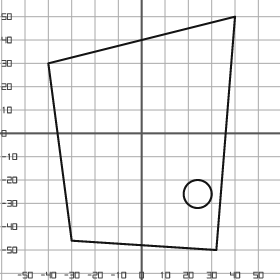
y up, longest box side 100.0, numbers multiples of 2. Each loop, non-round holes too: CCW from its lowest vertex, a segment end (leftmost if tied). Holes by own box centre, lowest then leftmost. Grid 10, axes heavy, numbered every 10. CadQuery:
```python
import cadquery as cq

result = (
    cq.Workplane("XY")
    .moveTo(32.0, -50.0)
    .lineTo(40.0, 50.0)
    .lineTo(-40.0, 30.0)
    .lineTo(-30.0, -46.0)
    .close()
    .moveTo(24.0, -26.0)
    .circle(6.0)
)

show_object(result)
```